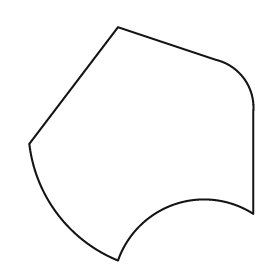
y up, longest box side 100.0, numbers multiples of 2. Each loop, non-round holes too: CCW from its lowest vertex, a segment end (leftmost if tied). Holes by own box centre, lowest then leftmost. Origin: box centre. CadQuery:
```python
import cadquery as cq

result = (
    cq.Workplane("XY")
    .moveTo(-10.0, -50.0)
    .threePointArc((14.0, -26.0), (48.0, -30.0))
    .lineTo(48.0, 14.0)
    .threePointArc((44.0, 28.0), (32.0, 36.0))
    .lineTo(-10.0, 50.0)
    .lineTo(-48.0, 0.0)
    .threePointArc((-36.0, -30.0), (-10.0, -50.0))
    .close()
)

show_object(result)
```